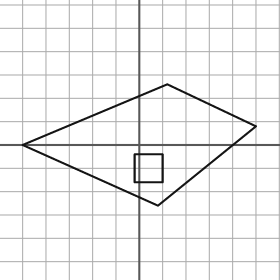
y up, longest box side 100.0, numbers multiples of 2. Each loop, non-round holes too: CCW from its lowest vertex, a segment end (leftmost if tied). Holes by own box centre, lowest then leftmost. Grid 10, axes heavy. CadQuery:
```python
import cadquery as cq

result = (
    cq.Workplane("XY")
    .moveTo(8.0, -26.0)
    .lineTo(50.0, 8.0)
    .lineTo(12.0, 26.0)
    .lineTo(-50.0, 0.0)
    .close()
    .moveTo(-2.0, -16.0)
    .lineTo(10.0, -16.0)
    .lineTo(10.0, -4.0)
    .lineTo(-2.0, -4.0)
    .close()
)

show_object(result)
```